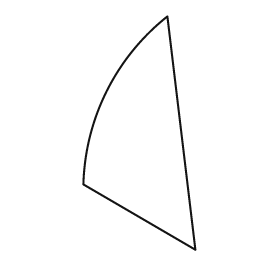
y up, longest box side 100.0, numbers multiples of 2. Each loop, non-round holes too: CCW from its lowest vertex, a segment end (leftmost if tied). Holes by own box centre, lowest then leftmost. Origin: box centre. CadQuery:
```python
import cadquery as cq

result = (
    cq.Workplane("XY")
    .moveTo(24.0, -50.0)
    .lineTo(12.0, 50.0)
    .threePointArc((-14.0, 18.0), (-24.0, -22.0))
    .close()
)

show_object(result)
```